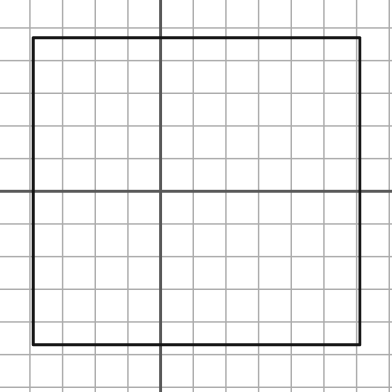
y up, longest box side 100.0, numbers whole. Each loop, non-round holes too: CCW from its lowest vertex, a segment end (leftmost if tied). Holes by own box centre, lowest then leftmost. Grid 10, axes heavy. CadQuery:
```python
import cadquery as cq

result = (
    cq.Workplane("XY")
    .moveTo(-39.0, -47.0)
    .lineTo(61.0, -47.0)
    .lineTo(61.0, 47.0)
    .lineTo(-39.0, 47.0)
    .close()
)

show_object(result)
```